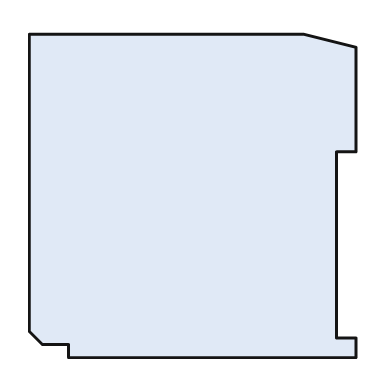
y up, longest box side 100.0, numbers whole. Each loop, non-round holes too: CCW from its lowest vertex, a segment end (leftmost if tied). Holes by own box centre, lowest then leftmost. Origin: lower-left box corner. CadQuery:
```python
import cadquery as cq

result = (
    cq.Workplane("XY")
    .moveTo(12.0, 0.0)
    .lineTo(100.0, 0.0)
    .lineTo(100.0, 6.0)
    .lineTo(94.0, 6.0)
    .lineTo(94.0, 63.0)
    .lineTo(100.0, 63.0)
    .lineTo(100.0, 95.0)
    .lineTo(84.0, 99.0)
    .lineTo(0.0, 99.0)
    .lineTo(0.0, 8.0)
    .lineTo(4.0, 4.0)
    .lineTo(12.0, 4.0)
    .close()
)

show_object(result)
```